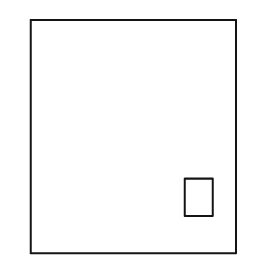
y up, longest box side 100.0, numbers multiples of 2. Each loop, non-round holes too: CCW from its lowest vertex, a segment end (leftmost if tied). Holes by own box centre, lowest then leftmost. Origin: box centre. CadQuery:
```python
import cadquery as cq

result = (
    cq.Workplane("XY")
    .moveTo(-44.0, -50.0)
    .lineTo(44.0, -50.0)
    .lineTo(44.0, 50.0)
    .lineTo(-44.0, 50.0)
    .close()
    .moveTo(22.0, -34.0)
    .lineTo(34.0, -34.0)
    .lineTo(34.0, -18.0)
    .lineTo(22.0, -18.0)
    .close()
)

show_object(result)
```